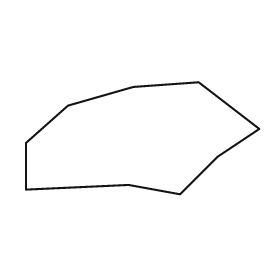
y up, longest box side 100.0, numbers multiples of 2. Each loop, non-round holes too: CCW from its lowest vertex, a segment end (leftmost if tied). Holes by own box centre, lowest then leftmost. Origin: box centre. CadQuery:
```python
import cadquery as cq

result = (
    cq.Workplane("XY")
    .moveTo(16.0, -24.0)
    .lineTo(32.0, -8.0)
    .lineTo(50.0, 4.0)
    .lineTo(24.0, 24.0)
    .lineTo(-4.0, 22.0)
    .lineTo(-32.0, 14.0)
    .lineTo(-50.0, -2.0)
    .lineTo(-50.0, -22.0)
    .lineTo(-6.0, -20.0)
    .close()
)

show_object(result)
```